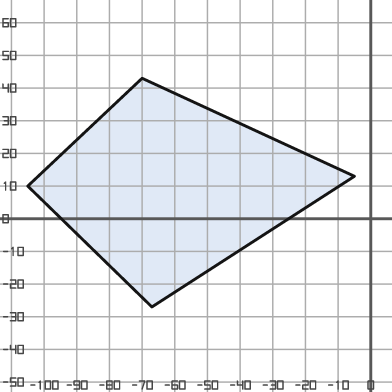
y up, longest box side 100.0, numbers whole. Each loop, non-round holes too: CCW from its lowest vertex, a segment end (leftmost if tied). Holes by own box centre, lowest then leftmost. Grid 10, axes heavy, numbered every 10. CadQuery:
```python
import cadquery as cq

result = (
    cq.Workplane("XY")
    .moveTo(-67.0, -27.0)
    .lineTo(-5.0, 13.0)
    .lineTo(-70.0, 43.0)
    .lineTo(-105.0, 10.0)
    .close()
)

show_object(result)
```